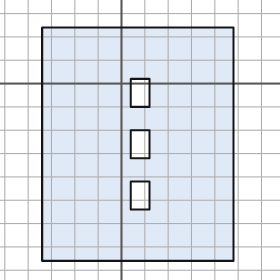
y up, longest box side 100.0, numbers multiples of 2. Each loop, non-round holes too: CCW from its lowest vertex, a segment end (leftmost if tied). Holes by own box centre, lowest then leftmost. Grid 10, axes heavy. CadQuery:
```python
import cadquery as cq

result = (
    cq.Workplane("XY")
    .moveTo(-34.0, -76.0)
    .lineTo(48.0, -76.0)
    .lineTo(48.0, 24.0)
    .lineTo(-34.0, 24.0)
    .close()
    .moveTo(4.0, -54.0)
    .lineTo(12.0, -54.0)
    .lineTo(12.0, -42.0)
    .lineTo(4.0, -42.0)
    .close()
    .moveTo(4.0, -32.0)
    .lineTo(12.0, -32.0)
    .lineTo(12.0, -20.0)
    .lineTo(4.0, -20.0)
    .close()
    .moveTo(4.0, -10.0)
    .lineTo(12.0, -10.0)
    .lineTo(12.0, 2.0)
    .lineTo(4.0, 2.0)
    .close()
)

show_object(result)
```